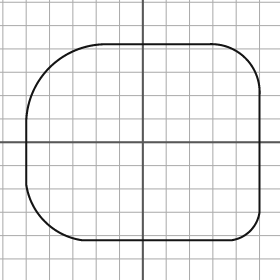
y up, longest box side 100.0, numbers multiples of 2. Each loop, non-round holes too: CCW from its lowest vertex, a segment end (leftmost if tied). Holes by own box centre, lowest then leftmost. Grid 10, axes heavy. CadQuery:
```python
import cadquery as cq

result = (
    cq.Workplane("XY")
    .moveTo(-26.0, -42.0)
    .lineTo(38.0, -42.0)
    .threePointArc((46.0, -38.0), (50.0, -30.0))
    .lineTo(50.0, 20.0)
    .threePointArc((44.0, 36.0), (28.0, 42.0))
    .lineTo(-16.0, 42.0)
    .threePointArc((-40.0, 32.0), (-50.0, 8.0))
    .lineTo(-50.0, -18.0)
    .threePointArc((-42.0, -34.0), (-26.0, -42.0))
    .close()
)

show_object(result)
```